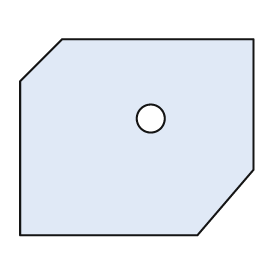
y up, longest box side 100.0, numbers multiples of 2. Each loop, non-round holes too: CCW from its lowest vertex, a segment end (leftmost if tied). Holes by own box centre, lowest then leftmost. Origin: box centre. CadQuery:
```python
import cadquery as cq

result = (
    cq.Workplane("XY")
    .moveTo(-50.0, -42.0)
    .lineTo(26.0, -42.0)
    .lineTo(50.0, -14.0)
    .lineTo(50.0, 42.0)
    .lineTo(-32.0, 42.0)
    .lineTo(-50.0, 24.0)
    .close()
    .moveTo(6.0, 8.0)
    .circle(6.0)
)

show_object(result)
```